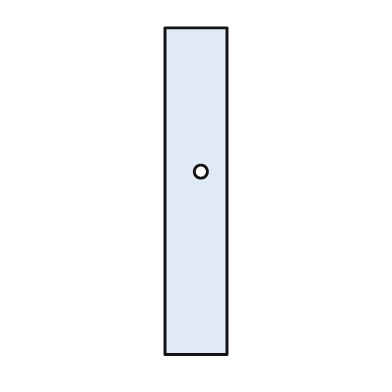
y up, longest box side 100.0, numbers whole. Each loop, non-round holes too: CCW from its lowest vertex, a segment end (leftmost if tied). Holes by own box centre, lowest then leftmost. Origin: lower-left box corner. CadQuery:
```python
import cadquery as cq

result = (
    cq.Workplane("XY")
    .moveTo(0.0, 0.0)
    .lineTo(19.0, 0.0)
    .lineTo(19.0, 100.0)
    .lineTo(0.0, 100.0)
    .close()
    .moveTo(11.0, 56.0)
    .circle(2.0)
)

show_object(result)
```